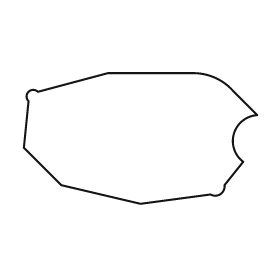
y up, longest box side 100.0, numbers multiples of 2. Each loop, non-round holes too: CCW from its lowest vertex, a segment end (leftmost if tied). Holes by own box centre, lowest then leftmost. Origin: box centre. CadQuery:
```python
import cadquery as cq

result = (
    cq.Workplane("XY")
    .moveTo(0.0, -28.0)
    .lineTo(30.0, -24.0)
    .threePointArc((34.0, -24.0), (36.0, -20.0))
    .lineTo(44.0, -10.0)
    .threePointArc((40.0, 2.0), (50.0, 10.0))
    .lineTo(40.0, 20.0)
    .threePointArc((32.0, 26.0), (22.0, 28.0))
    .lineTo(-14.0, 28.0)
    .lineTo(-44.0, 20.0)
    .threePointArc((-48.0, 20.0), (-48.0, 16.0))
    .lineTo(-50.0, -4.0)
    .lineTo(-34.0, -20.0)
    .close()
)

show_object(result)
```